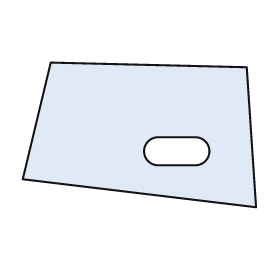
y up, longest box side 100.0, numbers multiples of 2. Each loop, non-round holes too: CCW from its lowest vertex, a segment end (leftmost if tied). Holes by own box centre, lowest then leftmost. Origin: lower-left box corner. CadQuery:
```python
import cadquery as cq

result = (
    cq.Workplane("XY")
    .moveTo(100.0, 0.0)
    .lineTo(96.0, 60.0)
    .lineTo(12.0, 62.0)
    .lineTo(0.0, 12.0)
    .close()
    .moveTo(58.0, 18.0)
    .lineTo(74.0, 18.0)
    .threePointArc((80.0, 24.0), (74.0, 30.0))
    .lineTo(58.0, 30.0)
    .threePointArc((52.0, 24.0), (58.0, 18.0))
    .close()
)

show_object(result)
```